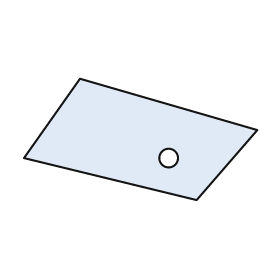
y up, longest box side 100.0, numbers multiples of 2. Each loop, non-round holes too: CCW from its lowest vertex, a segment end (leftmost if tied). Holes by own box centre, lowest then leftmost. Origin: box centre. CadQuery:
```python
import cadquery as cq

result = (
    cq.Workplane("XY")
    .moveTo(24.0, -26.0)
    .lineTo(50.0, 4.0)
    .lineTo(-26.0, 26.0)
    .lineTo(-50.0, -8.0)
    .close()
    .moveTo(12.0, -8.0)
    .circle(4.0)
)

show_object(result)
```